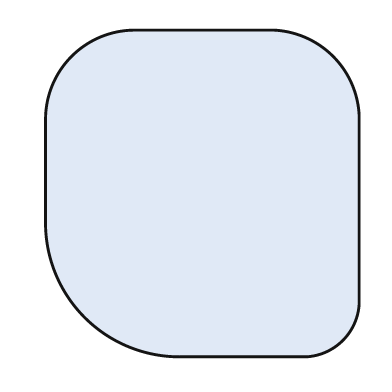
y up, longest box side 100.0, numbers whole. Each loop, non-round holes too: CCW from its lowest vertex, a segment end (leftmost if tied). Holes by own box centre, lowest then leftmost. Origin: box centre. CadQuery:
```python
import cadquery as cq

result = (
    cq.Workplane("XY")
    .moveTo(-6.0, -50.0)
    .lineTo(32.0, -50.0)
    .threePointArc((43.0, -45.0), (48.0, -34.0))
    .lineTo(48.0, 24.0)
    .threePointArc((40.0, 42.0), (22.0, 50.0))
    .lineTo(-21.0, 50.0)
    .threePointArc((-40.0, 42.0), (-48.0, 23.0))
    .lineTo(-48.0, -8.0)
    .threePointArc((-36.0, -38.0), (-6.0, -50.0))
    .close()
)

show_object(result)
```